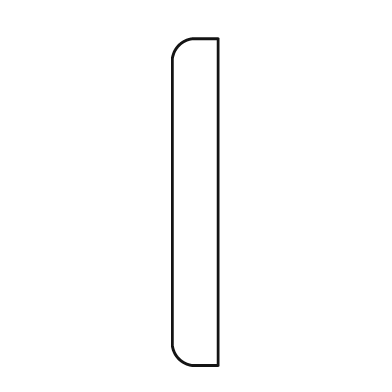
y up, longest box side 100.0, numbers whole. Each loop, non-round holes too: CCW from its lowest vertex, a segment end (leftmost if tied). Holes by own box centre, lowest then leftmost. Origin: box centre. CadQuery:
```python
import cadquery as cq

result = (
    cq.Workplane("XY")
    .moveTo(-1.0, -50.0)
    .lineTo(7.0, -50.0)
    .lineTo(7.0, 50.0)
    .lineTo(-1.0, 50.0)
    .threePointArc((-5.0, 48.0), (-7.0, 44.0))
    .lineTo(-7.0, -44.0)
    .threePointArc((-5.0, -48.0), (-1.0, -50.0))
    .close()
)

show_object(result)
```